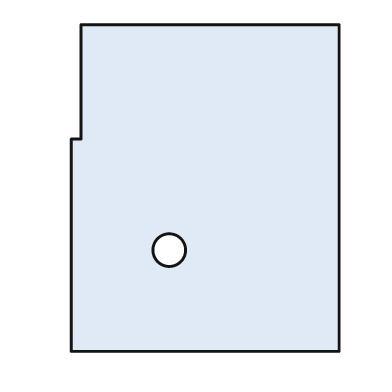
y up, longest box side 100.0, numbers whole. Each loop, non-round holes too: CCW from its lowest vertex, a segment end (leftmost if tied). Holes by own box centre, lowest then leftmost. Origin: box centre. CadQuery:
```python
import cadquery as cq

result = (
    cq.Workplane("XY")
    .moveTo(-41.0, -50.0)
    .lineTo(41.0, -50.0)
    .lineTo(41.0, 50.0)
    .lineTo(-38.0, 50.0)
    .lineTo(-38.0, 15.0)
    .lineTo(-41.0, 15.0)
    .close()
    .moveTo(-11.0, -19.0)
    .circle(5.0)
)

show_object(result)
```